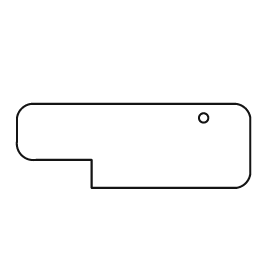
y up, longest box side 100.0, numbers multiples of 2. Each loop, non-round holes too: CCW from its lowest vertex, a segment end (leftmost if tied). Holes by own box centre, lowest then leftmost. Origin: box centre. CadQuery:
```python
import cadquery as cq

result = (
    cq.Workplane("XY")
    .moveTo(-18.0, -18.0)
    .lineTo(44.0, -18.0)
    .threePointArc((48.0, -16.0), (50.0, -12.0))
    .lineTo(50.0, 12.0)
    .threePointArc((48.0, 16.0), (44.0, 18.0))
    .lineTo(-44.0, 18.0)
    .threePointArc((-48.0, 16.0), (-50.0, 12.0))
    .lineTo(-50.0, 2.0)
    .threePointArc((-48.0, -4.0), (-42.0, -6.0))
    .lineTo(-18.0, -6.0)
    .close()
    .moveTo(30.0, 12.0)
    .circle(2.0)
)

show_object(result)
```